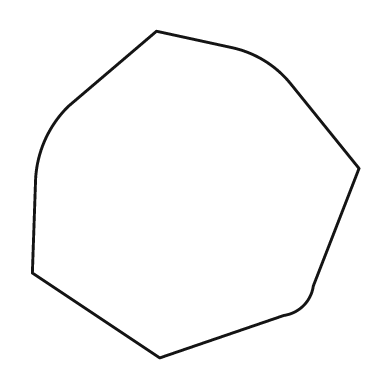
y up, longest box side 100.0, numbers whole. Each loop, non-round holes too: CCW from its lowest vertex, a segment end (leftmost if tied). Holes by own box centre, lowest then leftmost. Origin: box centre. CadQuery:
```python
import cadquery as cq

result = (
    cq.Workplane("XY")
    .moveTo(-11.0, -50.0)
    .lineTo(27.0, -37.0)
    .threePointArc((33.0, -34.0), (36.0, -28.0))
    .lineTo(50.0, 8.0)
    .lineTo(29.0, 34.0)
    .threePointArc((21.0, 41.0), (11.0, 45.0))
    .lineTo(-12.0, 50.0)
    .lineTo(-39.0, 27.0)
    .threePointArc((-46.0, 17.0), (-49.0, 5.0))
    .lineTo(-50.0, -24.0)
    .close()
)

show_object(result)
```